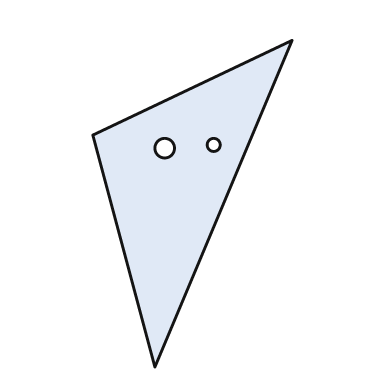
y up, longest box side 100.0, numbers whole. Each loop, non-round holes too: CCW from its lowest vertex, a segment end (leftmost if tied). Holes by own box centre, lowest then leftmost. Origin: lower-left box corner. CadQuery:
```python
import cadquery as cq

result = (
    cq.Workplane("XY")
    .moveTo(19.0, 0.0)
    .lineTo(61.0, 100.0)
    .lineTo(0.0, 71.0)
    .close()
    .moveTo(22.0, 67.0)
    .circle(3.0)
    .moveTo(37.0, 68.0)
    .circle(2.0)
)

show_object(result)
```